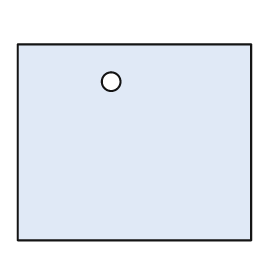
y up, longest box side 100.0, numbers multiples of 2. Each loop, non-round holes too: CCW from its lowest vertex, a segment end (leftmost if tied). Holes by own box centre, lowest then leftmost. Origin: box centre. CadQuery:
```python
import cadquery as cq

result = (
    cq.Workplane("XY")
    .moveTo(-50.0, -42.0)
    .lineTo(50.0, -42.0)
    .lineTo(50.0, 42.0)
    .lineTo(-50.0, 42.0)
    .close()
    .moveTo(-10.0, 26.0)
    .circle(4.0)
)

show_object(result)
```